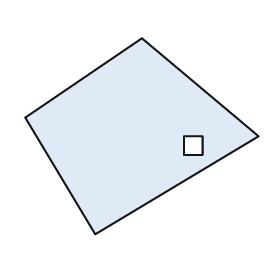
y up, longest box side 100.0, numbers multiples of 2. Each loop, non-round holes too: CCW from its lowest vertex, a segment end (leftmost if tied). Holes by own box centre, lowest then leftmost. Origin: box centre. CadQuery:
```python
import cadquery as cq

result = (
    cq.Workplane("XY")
    .moveTo(-20.0, -42.0)
    .lineTo(50.0, 0.0)
    .lineTo(0.0, 42.0)
    .lineTo(-50.0, 8.0)
    .close()
    .moveTo(18.0, -8.0)
    .lineTo(26.0, -8.0)
    .lineTo(26.0, 0.0)
    .lineTo(18.0, 0.0)
    .close()
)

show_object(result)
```